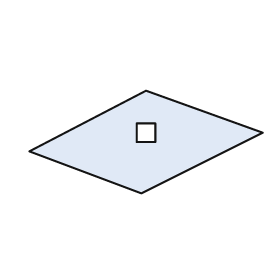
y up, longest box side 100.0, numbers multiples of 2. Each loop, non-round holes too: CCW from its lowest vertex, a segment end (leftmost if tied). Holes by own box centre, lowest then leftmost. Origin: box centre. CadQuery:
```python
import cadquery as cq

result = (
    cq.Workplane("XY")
    .moveTo(-2.0, -22.0)
    .lineTo(50.0, 4.0)
    .lineTo(0.0, 22.0)
    .lineTo(-50.0, -4.0)
    .close()
    .moveTo(-4.0, 0.0)
    .lineTo(4.0, 0.0)
    .lineTo(4.0, 8.0)
    .lineTo(-4.0, 8.0)
    .close()
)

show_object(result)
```